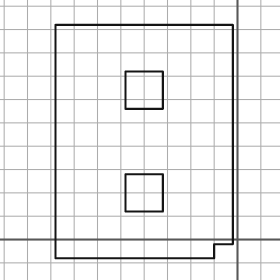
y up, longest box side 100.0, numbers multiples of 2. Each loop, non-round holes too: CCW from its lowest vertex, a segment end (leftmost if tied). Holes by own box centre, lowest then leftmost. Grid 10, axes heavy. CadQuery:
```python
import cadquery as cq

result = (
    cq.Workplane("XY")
    .moveTo(-78.0, -8.0)
    .lineTo(-10.0, -8.0)
    .lineTo(-10.0, -2.0)
    .lineTo(-2.0, -2.0)
    .lineTo(-2.0, 92.0)
    .lineTo(-78.0, 92.0)
    .close()
    .moveTo(-48.0, 12.0)
    .lineTo(-32.0, 12.0)
    .lineTo(-32.0, 28.0)
    .lineTo(-48.0, 28.0)
    .close()
    .moveTo(-48.0, 56.0)
    .lineTo(-32.0, 56.0)
    .lineTo(-32.0, 72.0)
    .lineTo(-48.0, 72.0)
    .close()
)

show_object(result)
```